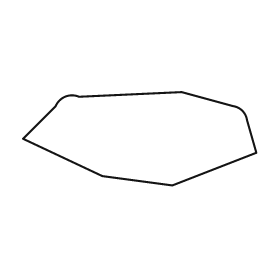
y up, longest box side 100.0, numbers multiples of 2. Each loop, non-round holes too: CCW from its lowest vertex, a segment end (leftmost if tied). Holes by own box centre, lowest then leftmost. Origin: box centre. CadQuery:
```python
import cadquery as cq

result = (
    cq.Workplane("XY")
    .moveTo(14.0, -20.0)
    .lineTo(50.0, -6.0)
    .lineTo(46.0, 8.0)
    .threePointArc((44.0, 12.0), (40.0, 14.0))
    .lineTo(18.0, 20.0)
    .lineTo(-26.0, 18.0)
    .threePointArc((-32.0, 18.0), (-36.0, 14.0))
    .lineTo(-50.0, 0.0)
    .lineTo(-16.0, -16.0)
    .close()
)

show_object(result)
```